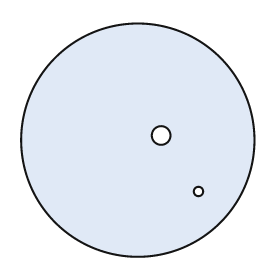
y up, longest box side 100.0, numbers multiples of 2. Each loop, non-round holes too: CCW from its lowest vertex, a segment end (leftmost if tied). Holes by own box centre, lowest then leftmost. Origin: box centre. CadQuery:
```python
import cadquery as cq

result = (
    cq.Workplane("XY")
    .moveTo(0.0, 0.0)
    .circle(50.0)
    .moveTo(26.0, -22.0)
    .circle(2.0)
    .moveTo(10.0, 2.0)
    .circle(4.0)
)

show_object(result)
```